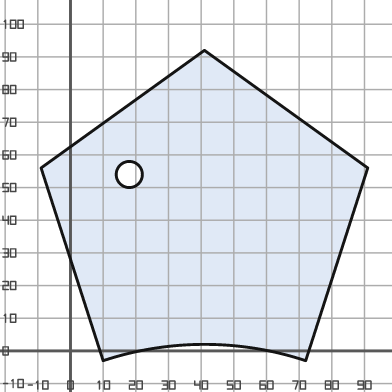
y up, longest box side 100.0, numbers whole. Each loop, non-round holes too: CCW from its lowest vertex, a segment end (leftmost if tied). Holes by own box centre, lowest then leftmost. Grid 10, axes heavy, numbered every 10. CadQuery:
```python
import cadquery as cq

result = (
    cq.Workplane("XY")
    .moveTo(10.0, -3.0)
    .threePointArc((41.0, 2.0), (72.0, -3.0))
    .lineTo(91.0, 56.0)
    .lineTo(41.0, 92.0)
    .lineTo(-9.0, 56.0)
    .close()
    .moveTo(18.0, 54.0)
    .circle(4.0)
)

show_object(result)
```